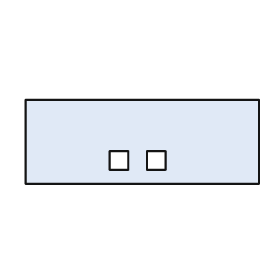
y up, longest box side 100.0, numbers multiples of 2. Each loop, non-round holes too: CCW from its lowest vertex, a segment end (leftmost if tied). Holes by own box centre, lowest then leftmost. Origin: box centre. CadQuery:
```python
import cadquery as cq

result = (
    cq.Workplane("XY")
    .moveTo(-50.0, -18.0)
    .lineTo(50.0, -18.0)
    .lineTo(50.0, 18.0)
    .lineTo(-50.0, 18.0)
    .close()
    .moveTo(-14.0, -12.0)
    .lineTo(-6.0, -12.0)
    .lineTo(-6.0, -4.0)
    .lineTo(-14.0, -4.0)
    .close()
    .moveTo(2.0, -12.0)
    .lineTo(10.0, -12.0)
    .lineTo(10.0, -4.0)
    .lineTo(2.0, -4.0)
    .close()
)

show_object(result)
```